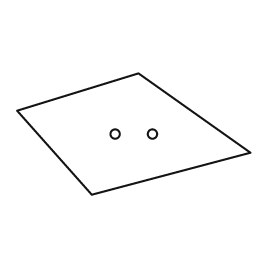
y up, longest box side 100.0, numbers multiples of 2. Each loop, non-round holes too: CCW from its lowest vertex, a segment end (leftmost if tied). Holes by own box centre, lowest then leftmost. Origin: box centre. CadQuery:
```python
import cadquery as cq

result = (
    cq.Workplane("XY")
    .moveTo(-18.0, -26.0)
    .lineTo(50.0, -8.0)
    .lineTo(2.0, 26.0)
    .lineTo(-50.0, 10.0)
    .close()
    .moveTo(-8.0, 0.0)
    .circle(2.0)
    .moveTo(8.0, 0.0)
    .circle(2.0)
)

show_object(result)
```